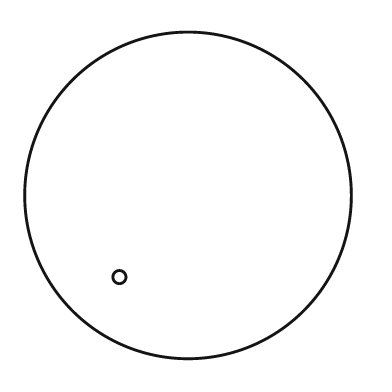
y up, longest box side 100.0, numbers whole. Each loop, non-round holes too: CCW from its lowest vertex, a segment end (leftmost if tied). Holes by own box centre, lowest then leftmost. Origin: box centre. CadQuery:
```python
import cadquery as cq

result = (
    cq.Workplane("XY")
    .moveTo(0.0, 0.0)
    .circle(50.0)
    .moveTo(-21.0, -25.0)
    .circle(2.0)
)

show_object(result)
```